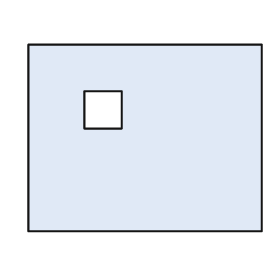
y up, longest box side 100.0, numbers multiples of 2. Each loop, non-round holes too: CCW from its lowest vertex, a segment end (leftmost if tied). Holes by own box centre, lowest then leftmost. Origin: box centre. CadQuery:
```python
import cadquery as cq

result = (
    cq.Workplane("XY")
    .moveTo(-50.0, -40.0)
    .lineTo(50.0, -40.0)
    .lineTo(50.0, 40.0)
    .lineTo(-50.0, 40.0)
    .close()
    .moveTo(-26.0, 4.0)
    .lineTo(-10.0, 4.0)
    .lineTo(-10.0, 20.0)
    .lineTo(-26.0, 20.0)
    .close()
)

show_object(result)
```